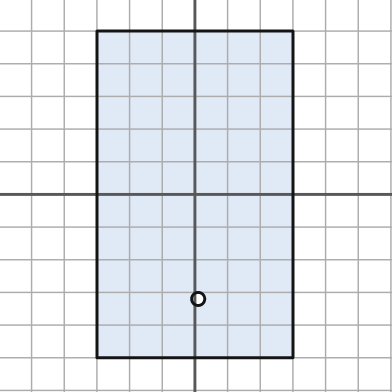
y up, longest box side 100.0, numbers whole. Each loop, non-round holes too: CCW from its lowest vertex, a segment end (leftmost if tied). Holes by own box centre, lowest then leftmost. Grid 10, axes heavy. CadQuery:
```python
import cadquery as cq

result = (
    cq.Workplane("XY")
    .moveTo(-30.0, -50.0)
    .lineTo(30.0, -50.0)
    .lineTo(30.0, 50.0)
    .lineTo(-30.0, 50.0)
    .close()
    .moveTo(1.0, -32.0)
    .circle(2.0)
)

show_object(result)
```